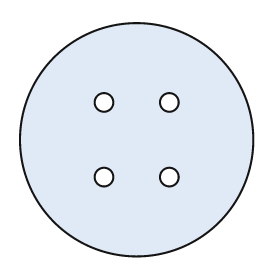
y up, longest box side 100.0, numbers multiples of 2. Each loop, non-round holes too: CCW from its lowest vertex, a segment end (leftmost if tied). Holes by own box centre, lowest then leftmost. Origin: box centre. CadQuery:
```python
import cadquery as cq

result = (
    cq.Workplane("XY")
    .moveTo(0.0, 0.0)
    .circle(50.0)
    .moveTo(-14.0, -16.0)
    .circle(4.0)
    .moveTo(14.0, -16.0)
    .circle(4.0)
    .moveTo(-14.0, 16.0)
    .circle(4.0)
    .moveTo(14.0, 16.0)
    .circle(4.0)
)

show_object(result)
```